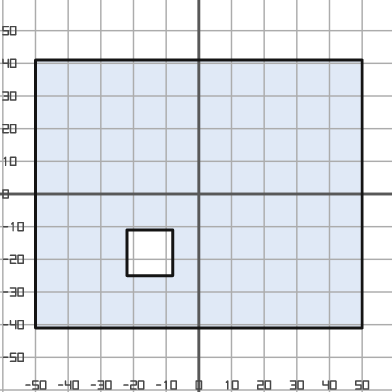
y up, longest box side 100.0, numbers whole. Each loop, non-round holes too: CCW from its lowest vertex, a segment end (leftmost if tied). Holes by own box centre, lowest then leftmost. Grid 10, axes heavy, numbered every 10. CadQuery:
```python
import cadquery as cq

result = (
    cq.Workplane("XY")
    .moveTo(-50.0, -41.0)
    .lineTo(50.0, -41.0)
    .lineTo(50.0, 41.0)
    .lineTo(-50.0, 41.0)
    .close()
    .moveTo(-22.0, -25.0)
    .lineTo(-8.0, -25.0)
    .lineTo(-8.0, -11.0)
    .lineTo(-22.0, -11.0)
    .close()
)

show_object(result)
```